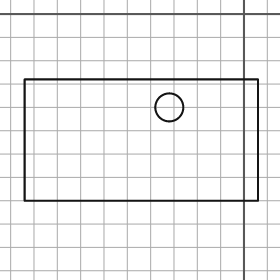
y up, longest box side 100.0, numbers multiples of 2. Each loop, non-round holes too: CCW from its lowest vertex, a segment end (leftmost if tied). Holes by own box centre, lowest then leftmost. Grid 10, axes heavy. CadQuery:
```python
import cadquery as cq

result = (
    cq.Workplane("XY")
    .moveTo(-94.0, -80.0)
    .lineTo(6.0, -80.0)
    .lineTo(6.0, -28.0)
    .lineTo(-94.0, -28.0)
    .close()
    .moveTo(-32.0, -40.0)
    .circle(6.0)
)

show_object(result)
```